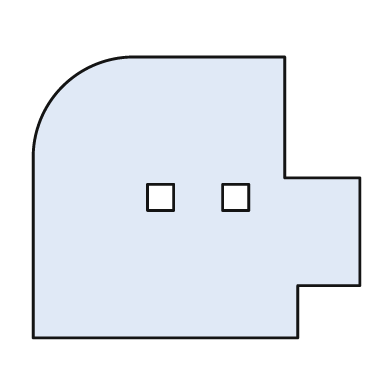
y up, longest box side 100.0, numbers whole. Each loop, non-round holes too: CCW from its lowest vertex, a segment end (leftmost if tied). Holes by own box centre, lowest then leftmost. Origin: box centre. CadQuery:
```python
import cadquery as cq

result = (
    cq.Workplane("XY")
    .moveTo(-50.0, -43.0)
    .lineTo(31.0, -43.0)
    .lineTo(31.0, -27.0)
    .lineTo(50.0, -27.0)
    .lineTo(50.0, 6.0)
    .lineTo(27.0, 6.0)
    .lineTo(27.0, 43.0)
    .lineTo(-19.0, 43.0)
    .threePointArc((-41.0, 34.0), (-50.0, 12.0))
    .close()
    .moveTo(-15.0, -4.0)
    .lineTo(-7.0, -4.0)
    .lineTo(-7.0, 4.0)
    .lineTo(-15.0, 4.0)
    .close()
    .moveTo(8.0, -4.0)
    .lineTo(16.0, -4.0)
    .lineTo(16.0, 4.0)
    .lineTo(8.0, 4.0)
    .close()
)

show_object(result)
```